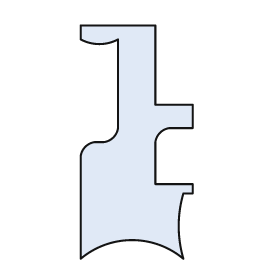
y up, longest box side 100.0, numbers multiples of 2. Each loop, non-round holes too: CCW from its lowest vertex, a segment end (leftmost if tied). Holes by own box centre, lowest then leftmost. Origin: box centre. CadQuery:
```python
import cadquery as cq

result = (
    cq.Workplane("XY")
    .moveTo(-24.0, -50.0)
    .threePointArc((-2.0, -42.0), (20.0, -50.0))
    .threePointArc((18.0, -36.0), (20.0, -22.0))
    .lineTo(24.0, -22.0)
    .lineTo(24.0, -18.0)
    .lineTo(8.0, -18.0)
    .lineTo(8.0, 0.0)
    .threePointArc((10.0, 4.0), (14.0, 6.0))
    .lineTo(24.0, 6.0)
    .lineTo(24.0, 16.0)
    .lineTo(8.0, 16.0)
    .lineTo(8.0, 50.0)
    .lineTo(-24.0, 50.0)
    .lineTo(-24.0, 44.0)
    .threePointArc((-16.0, 42.0), (-8.0, 44.0))
    .lineTo(-8.0, 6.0)
    .threePointArc((-10.0, 2.0), (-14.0, 0.0))
    .lineTo(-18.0, 0.0)
    .threePointArc((-22.0, -2.0), (-24.0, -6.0))
    .close()
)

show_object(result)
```